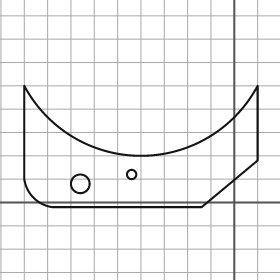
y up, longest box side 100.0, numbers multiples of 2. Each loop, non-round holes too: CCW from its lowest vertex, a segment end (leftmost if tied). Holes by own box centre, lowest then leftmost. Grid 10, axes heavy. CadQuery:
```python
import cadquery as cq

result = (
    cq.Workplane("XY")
    .moveTo(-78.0, -2.0)
    .lineTo(-14.0, -2.0)
    .lineTo(10.0, 18.0)
    .lineTo(10.0, 50.0)
    .threePointArc((-40.0, 20.0), (-90.0, 50.0))
    .lineTo(-90.0, 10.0)
    .threePointArc((-86.0, 2.0), (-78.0, -2.0))
    .close()
    .moveTo(-66.0, 8.0)
    .circle(4.0)
    .moveTo(-44.0, 12.0)
    .circle(2.0)
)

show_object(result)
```